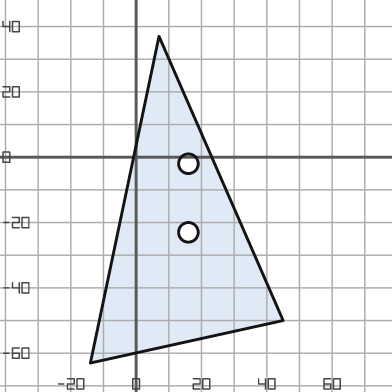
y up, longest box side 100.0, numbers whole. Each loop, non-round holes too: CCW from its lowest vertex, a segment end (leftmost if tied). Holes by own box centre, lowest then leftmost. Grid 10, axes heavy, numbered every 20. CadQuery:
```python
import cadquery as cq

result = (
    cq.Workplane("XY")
    .moveTo(-14.0, -63.0)
    .lineTo(45.0, -50.0)
    .lineTo(7.0, 37.0)
    .close()
    .moveTo(16.0, -23.0)
    .circle(3.0)
    .moveTo(16.0, -2.0)
    .circle(3.0)
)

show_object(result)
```